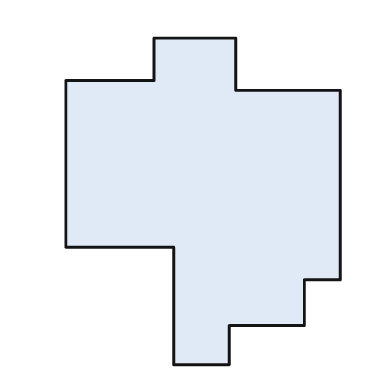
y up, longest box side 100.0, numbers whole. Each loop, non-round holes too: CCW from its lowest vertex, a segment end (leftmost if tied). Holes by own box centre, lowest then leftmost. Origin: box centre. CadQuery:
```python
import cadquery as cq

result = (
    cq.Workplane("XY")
    .moveTo(-9.0, -50.0)
    .lineTo(8.0, -50.0)
    .lineTo(8.0, -38.0)
    .lineTo(31.0, -38.0)
    .lineTo(31.0, -24.0)
    .lineTo(42.0, -24.0)
    .lineTo(42.0, 34.0)
    .lineTo(10.0, 34.0)
    .lineTo(10.0, 50.0)
    .lineTo(-15.0, 50.0)
    .lineTo(-15.0, 37.0)
    .lineTo(-42.0, 37.0)
    .lineTo(-42.0, -14.0)
    .lineTo(-9.0, -14.0)
    .close()
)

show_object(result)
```